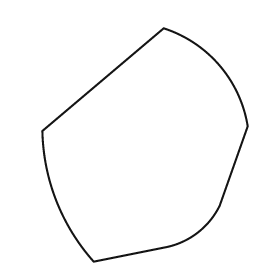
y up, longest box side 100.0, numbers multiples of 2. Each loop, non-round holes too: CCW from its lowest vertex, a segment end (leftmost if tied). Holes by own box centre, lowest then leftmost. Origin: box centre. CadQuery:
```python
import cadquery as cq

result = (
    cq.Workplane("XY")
    .moveTo(-22.0, -50.0)
    .lineTo(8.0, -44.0)
    .threePointArc((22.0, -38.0), (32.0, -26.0))
    .lineTo(44.0, 8.0)
    .threePointArc((32.0, 34.0), (8.0, 50.0))
    .lineTo(-44.0, 6.0)
    .threePointArc((-38.0, -24.0), (-22.0, -50.0))
    .close()
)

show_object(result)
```